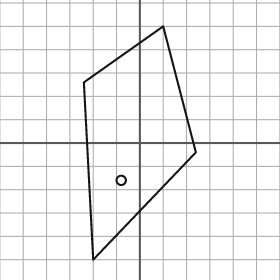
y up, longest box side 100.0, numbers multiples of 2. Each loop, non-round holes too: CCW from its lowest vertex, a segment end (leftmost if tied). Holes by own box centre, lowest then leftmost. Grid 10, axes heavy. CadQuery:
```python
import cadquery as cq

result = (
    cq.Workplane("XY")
    .moveTo(-20.0, -50.0)
    .lineTo(24.0, -4.0)
    .lineTo(10.0, 50.0)
    .lineTo(-24.0, 26.0)
    .close()
    .moveTo(-8.0, -16.0)
    .circle(2.0)
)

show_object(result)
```